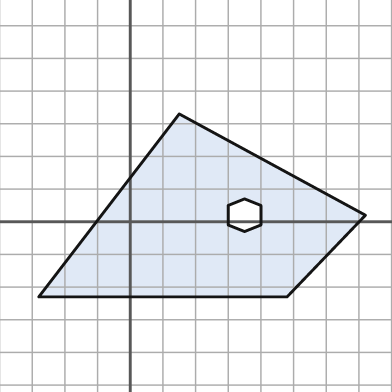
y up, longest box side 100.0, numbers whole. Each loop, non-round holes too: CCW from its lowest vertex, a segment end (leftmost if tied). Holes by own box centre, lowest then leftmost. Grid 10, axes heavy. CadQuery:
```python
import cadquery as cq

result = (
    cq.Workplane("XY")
    .moveTo(-28.0, -23.0)
    .lineTo(48.0, -23.0)
    .lineTo(72.0, 2.0)
    .lineTo(15.0, 33.0)
    .close()
    .moveTo(35.0, -3.0)
    .lineTo(40.0, -1.0)
    .lineTo(40.0, 5.0)
    .lineTo(35.0, 7.0)
    .lineTo(30.0, 5.0)
    .lineTo(30.0, -1.0)
    .close()
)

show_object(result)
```